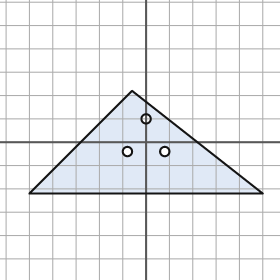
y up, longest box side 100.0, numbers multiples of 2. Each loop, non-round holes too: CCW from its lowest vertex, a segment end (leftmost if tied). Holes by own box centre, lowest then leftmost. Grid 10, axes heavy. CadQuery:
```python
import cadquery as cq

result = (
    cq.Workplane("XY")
    .moveTo(-50.0, -22.0)
    .lineTo(50.0, -22.0)
    .lineTo(-6.0, 22.0)
    .close()
    .moveTo(-8.0, -4.0)
    .circle(2.0)
    .moveTo(8.0, -4.0)
    .circle(2.0)
    .moveTo(0.0, 10.0)
    .circle(2.0)
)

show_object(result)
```